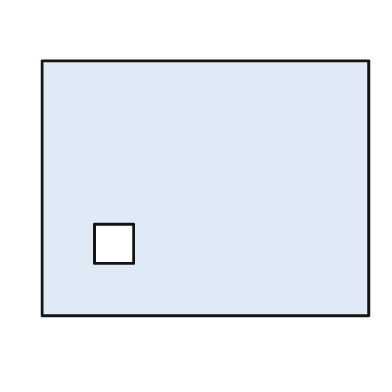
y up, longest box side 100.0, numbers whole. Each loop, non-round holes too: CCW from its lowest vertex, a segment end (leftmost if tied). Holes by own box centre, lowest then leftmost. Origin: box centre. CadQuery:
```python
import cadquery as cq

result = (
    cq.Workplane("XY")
    .moveTo(-50.0, -39.0)
    .lineTo(50.0, -39.0)
    .lineTo(50.0, 39.0)
    .lineTo(-50.0, 39.0)
    .close()
    .moveTo(-34.0, -23.0)
    .lineTo(-22.0, -23.0)
    .lineTo(-22.0, -11.0)
    .lineTo(-34.0, -11.0)
    .close()
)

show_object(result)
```